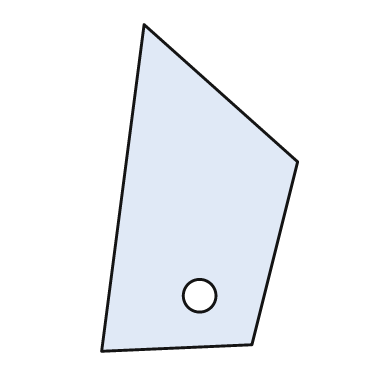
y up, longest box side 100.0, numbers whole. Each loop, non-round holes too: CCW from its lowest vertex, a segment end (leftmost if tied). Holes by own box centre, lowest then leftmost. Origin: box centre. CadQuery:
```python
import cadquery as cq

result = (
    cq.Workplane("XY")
    .moveTo(-30.0, -50.0)
    .lineTo(16.0, -48.0)
    .lineTo(30.0, 8.0)
    .lineTo(-17.0, 50.0)
    .close()
    .moveTo(0.0, -33.0)
    .circle(5.0)
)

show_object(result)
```